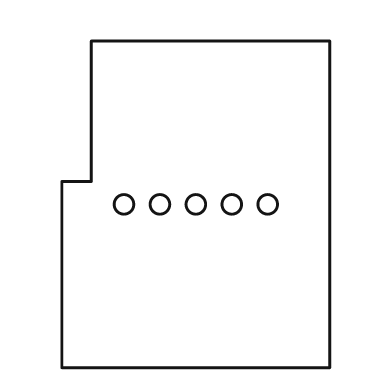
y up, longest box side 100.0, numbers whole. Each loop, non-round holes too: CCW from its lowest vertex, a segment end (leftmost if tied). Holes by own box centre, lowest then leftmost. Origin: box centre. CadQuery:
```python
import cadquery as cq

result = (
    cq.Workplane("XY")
    .moveTo(-41.0, -50.0)
    .lineTo(41.0, -50.0)
    .lineTo(41.0, 50.0)
    .lineTo(-32.0, 50.0)
    .lineTo(-32.0, 7.0)
    .lineTo(-41.0, 7.0)
    .close()
    .moveTo(-22.0, 0.0)
    .circle(3.0)
    .moveTo(-11.0, 0.0)
    .circle(3.0)
    .moveTo(0.0, 0.0)
    .circle(3.0)
    .moveTo(11.0, 0.0)
    .circle(3.0)
    .moveTo(22.0, 0.0)
    .circle(3.0)
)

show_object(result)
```